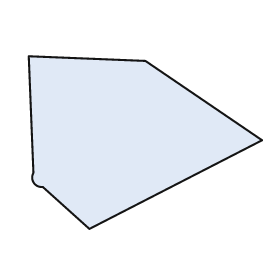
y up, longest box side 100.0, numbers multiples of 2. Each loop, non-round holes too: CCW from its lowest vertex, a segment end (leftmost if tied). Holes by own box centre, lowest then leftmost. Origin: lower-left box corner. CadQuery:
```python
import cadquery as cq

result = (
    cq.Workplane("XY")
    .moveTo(26.0, 0.0)
    .lineTo(100.0, 38.0)
    .lineTo(50.0, 72.0)
    .lineTo(0.0, 74.0)
    .lineTo(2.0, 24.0)
    .threePointArc((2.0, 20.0), (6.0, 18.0))
    .close()
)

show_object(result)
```